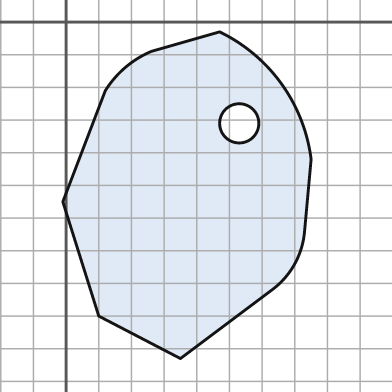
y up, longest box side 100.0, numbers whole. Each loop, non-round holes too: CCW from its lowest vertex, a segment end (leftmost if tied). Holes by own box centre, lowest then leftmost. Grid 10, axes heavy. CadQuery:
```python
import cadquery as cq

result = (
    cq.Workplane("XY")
    .moveTo(35.0, -103.0)
    .lineTo(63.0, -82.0)
    .threePointArc((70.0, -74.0), (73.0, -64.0))
    .lineTo(75.0, -42.0)
    .threePointArc((66.0, -19.0), (47.0, -3.0))
    .lineTo(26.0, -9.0)
    .threePointArc((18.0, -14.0), (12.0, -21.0))
    .lineTo(-1.0, -55.0)
    .lineTo(10.0, -90.0)
    .close()
    .moveTo(53.0, -31.0)
    .circle(6.0)
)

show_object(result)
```